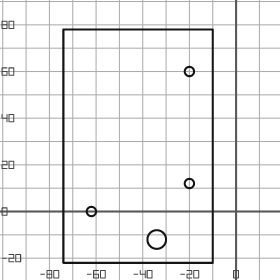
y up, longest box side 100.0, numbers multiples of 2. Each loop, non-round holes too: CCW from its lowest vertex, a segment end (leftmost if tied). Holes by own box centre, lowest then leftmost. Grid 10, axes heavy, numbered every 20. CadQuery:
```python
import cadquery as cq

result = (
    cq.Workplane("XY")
    .moveTo(-74.0, -22.0)
    .lineTo(-10.0, -22.0)
    .lineTo(-10.0, 78.0)
    .lineTo(-74.0, 78.0)
    .close()
    .moveTo(-34.0, -12.0)
    .circle(4.0)
    .moveTo(-62.0, 0.0)
    .circle(2.0)
    .moveTo(-20.0, 12.0)
    .circle(2.0)
    .moveTo(-20.0, 60.0)
    .circle(2.0)
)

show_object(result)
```